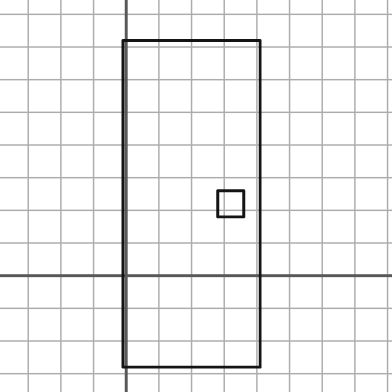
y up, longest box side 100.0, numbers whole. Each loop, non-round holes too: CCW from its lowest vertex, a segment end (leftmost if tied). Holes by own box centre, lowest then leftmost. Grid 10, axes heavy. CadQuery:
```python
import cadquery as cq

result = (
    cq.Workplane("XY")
    .moveTo(-1.0, -28.0)
    .lineTo(41.0, -28.0)
    .lineTo(41.0, 72.0)
    .lineTo(-1.0, 72.0)
    .close()
    .moveTo(28.0, 18.0)
    .lineTo(36.0, 18.0)
    .lineTo(36.0, 26.0)
    .lineTo(28.0, 26.0)
    .close()
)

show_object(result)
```